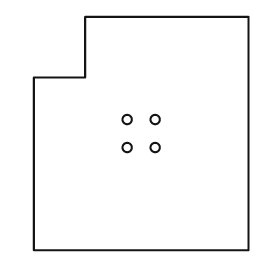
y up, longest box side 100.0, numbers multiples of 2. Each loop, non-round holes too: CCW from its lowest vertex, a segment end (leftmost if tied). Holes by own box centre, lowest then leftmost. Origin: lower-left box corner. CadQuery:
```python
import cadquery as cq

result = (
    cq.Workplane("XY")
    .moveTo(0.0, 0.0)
    .lineTo(92.0, 0.0)
    .lineTo(92.0, 100.0)
    .lineTo(22.0, 100.0)
    .lineTo(22.0, 74.0)
    .lineTo(0.0, 74.0)
    .close()
    .moveTo(40.0, 44.0)
    .circle(2.0)
    .moveTo(52.0, 44.0)
    .circle(2.0)
    .moveTo(40.0, 56.0)
    .circle(2.0)
    .moveTo(52.0, 56.0)
    .circle(2.0)
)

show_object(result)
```